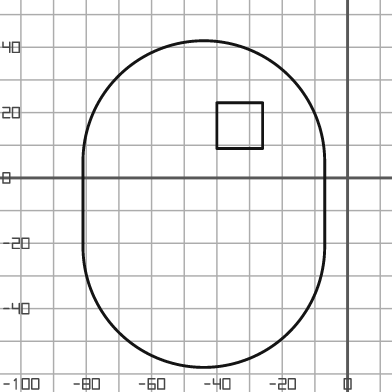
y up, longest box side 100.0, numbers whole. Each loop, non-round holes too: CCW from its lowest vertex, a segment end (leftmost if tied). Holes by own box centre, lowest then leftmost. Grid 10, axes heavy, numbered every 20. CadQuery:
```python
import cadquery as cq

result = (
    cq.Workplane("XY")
    .moveTo(-81.0, -21.0)
    .threePointArc((-44.0, -58.0), (-7.0, -21.0))
    .lineTo(-7.0, 5.0)
    .threePointArc((-44.0, 42.0), (-81.0, 5.0))
    .close()
    .moveTo(-40.0, 9.0)
    .lineTo(-26.0, 9.0)
    .lineTo(-26.0, 23.0)
    .lineTo(-40.0, 23.0)
    .close()
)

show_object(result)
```